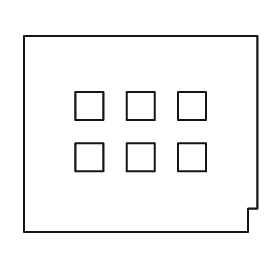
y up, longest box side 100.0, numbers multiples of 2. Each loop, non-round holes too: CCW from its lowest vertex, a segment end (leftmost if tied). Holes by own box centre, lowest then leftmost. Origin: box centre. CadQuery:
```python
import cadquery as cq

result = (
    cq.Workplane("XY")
    .moveTo(-50.0, -42.0)
    .lineTo(46.0, -42.0)
    .lineTo(46.0, -32.0)
    .lineTo(50.0, -32.0)
    .lineTo(50.0, 42.0)
    .lineTo(-50.0, 42.0)
    .close()
    .moveTo(-28.0, -16.0)
    .lineTo(-16.0, -16.0)
    .lineTo(-16.0, -4.0)
    .lineTo(-28.0, -4.0)
    .close()
    .moveTo(-6.0, -16.0)
    .lineTo(6.0, -16.0)
    .lineTo(6.0, -4.0)
    .lineTo(-6.0, -4.0)
    .close()
    .moveTo(16.0, -16.0)
    .lineTo(28.0, -16.0)
    .lineTo(28.0, -4.0)
    .lineTo(16.0, -4.0)
    .close()
    .moveTo(-28.0, 6.0)
    .lineTo(-16.0, 6.0)
    .lineTo(-16.0, 18.0)
    .lineTo(-28.0, 18.0)
    .close()
    .moveTo(-6.0, 6.0)
    .lineTo(6.0, 6.0)
    .lineTo(6.0, 18.0)
    .lineTo(-6.0, 18.0)
    .close()
    .moveTo(16.0, 6.0)
    .lineTo(28.0, 6.0)
    .lineTo(28.0, 18.0)
    .lineTo(16.0, 18.0)
    .close()
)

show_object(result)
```